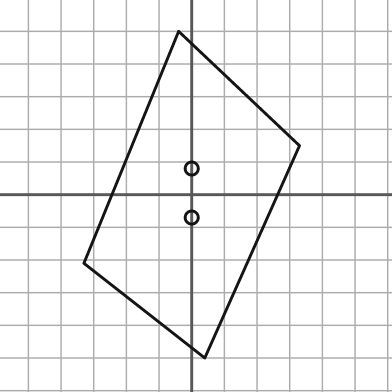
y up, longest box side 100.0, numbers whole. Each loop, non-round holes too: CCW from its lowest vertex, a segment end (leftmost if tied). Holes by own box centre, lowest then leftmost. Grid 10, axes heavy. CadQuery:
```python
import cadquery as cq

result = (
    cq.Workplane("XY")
    .moveTo(4.0, -50.0)
    .lineTo(33.0, 15.0)
    .lineTo(-4.0, 50.0)
    .lineTo(-33.0, -21.0)
    .close()
    .moveTo(0.0, -7.0)
    .circle(2.0)
    .moveTo(0.0, 8.0)
    .circle(2.0)
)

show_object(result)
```